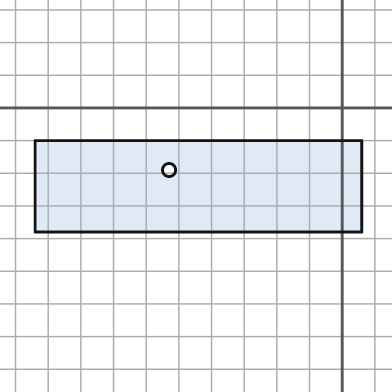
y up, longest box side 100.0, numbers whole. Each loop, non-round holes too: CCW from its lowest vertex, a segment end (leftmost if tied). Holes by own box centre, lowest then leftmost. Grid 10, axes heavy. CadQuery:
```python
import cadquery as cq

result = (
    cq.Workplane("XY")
    .moveTo(-94.0, -38.0)
    .lineTo(6.0, -38.0)
    .lineTo(6.0, -10.0)
    .lineTo(-94.0, -10.0)
    .close()
    .moveTo(-53.0, -19.0)
    .circle(2.0)
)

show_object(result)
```